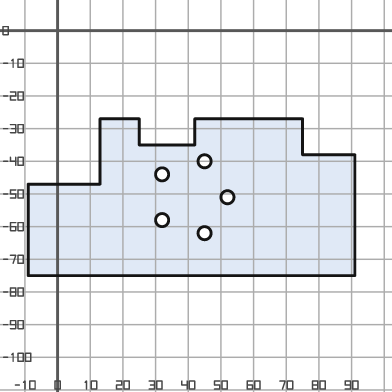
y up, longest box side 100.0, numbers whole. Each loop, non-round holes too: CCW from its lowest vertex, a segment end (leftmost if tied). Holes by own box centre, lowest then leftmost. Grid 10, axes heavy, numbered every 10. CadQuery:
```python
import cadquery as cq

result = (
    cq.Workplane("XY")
    .moveTo(-9.0, -75.0)
    .lineTo(91.0, -75.0)
    .lineTo(91.0, -38.0)
    .lineTo(75.0, -38.0)
    .lineTo(75.0, -27.0)
    .lineTo(42.0, -27.0)
    .lineTo(42.0, -35.0)
    .lineTo(25.0, -35.0)
    .lineTo(25.0, -27.0)
    .lineTo(13.0, -27.0)
    .lineTo(13.0, -47.0)
    .lineTo(-9.0, -47.0)
    .close()
    .moveTo(45.0, -62.0)
    .circle(2.0)
    .moveTo(32.0, -58.0)
    .circle(2.0)
    .moveTo(52.0, -51.0)
    .circle(2.0)
    .moveTo(32.0, -44.0)
    .circle(2.0)
    .moveTo(45.0, -40.0)
    .circle(2.0)
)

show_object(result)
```